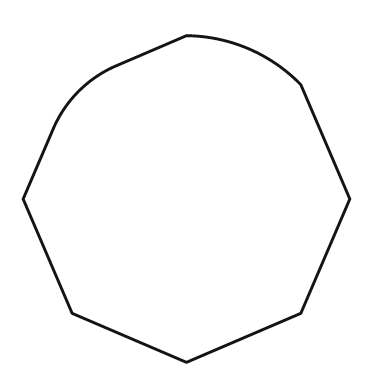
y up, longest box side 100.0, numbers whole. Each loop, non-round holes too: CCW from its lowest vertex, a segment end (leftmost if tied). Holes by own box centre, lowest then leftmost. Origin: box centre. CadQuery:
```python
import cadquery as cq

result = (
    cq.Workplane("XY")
    .moveTo(0.0, -50.0)
    .lineTo(35.0, -35.0)
    .lineTo(50.0, 0.0)
    .lineTo(35.0, 35.0)
    .threePointArc((19.0, 46.0), (0.0, 50.0))
    .lineTo(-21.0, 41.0)
    .threePointArc((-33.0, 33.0), (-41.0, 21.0))
    .lineTo(-50.0, 0.0)
    .lineTo(-35.0, -35.0)
    .close()
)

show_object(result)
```